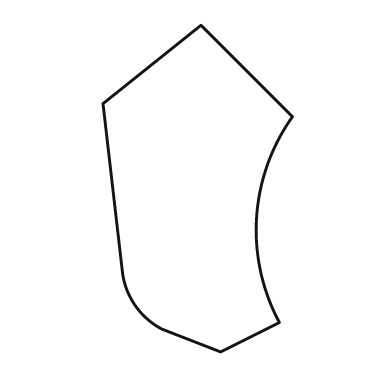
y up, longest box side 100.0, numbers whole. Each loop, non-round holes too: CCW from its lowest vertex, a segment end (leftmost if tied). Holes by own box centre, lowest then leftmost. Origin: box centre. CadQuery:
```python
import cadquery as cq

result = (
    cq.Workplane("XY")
    .moveTo(7.0, -50.0)
    .lineTo(25.0, -41.0)
    .threePointArc((18.0, -9.0), (29.0, 22.0))
    .lineTo(1.0, 50.0)
    .lineTo(-29.0, 26.0)
    .lineTo(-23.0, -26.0)
    .threePointArc((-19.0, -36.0), (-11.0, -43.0))
    .close()
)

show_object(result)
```